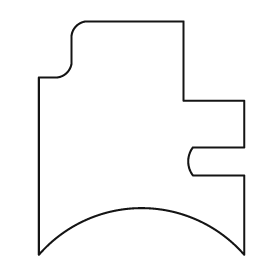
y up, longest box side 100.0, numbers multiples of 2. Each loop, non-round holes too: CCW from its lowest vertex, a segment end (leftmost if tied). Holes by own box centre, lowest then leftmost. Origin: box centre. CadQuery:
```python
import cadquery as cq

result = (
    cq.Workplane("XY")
    .moveTo(-44.0, -50.0)
    .threePointArc((0.0, -30.0), (44.0, -50.0))
    .lineTo(44.0, -16.0)
    .lineTo(22.0, -16.0)
    .threePointArc((20.0, -10.0), (22.0, -4.0))
    .lineTo(44.0, -4.0)
    .lineTo(44.0, 16.0)
    .lineTo(18.0, 16.0)
    .lineTo(18.0, 50.0)
    .lineTo(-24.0, 50.0)
    .threePointArc((-28.0, 48.0), (-30.0, 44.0))
    .lineTo(-30.0, 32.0)
    .threePointArc((-32.0, 28.0), (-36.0, 26.0))
    .lineTo(-44.0, 26.0)
    .close()
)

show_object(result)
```